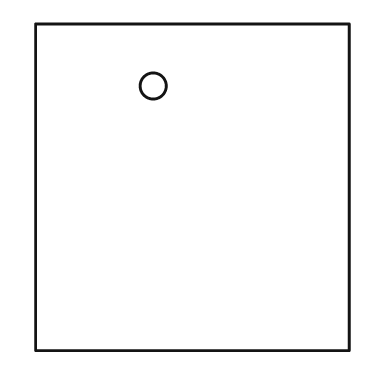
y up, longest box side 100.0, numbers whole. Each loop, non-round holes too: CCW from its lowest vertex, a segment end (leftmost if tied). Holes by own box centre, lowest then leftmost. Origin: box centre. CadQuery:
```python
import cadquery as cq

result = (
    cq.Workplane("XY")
    .moveTo(-48.0, -50.0)
    .lineTo(48.0, -50.0)
    .lineTo(48.0, 50.0)
    .lineTo(-48.0, 50.0)
    .close()
    .moveTo(-12.0, 31.0)
    .circle(4.0)
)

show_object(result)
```